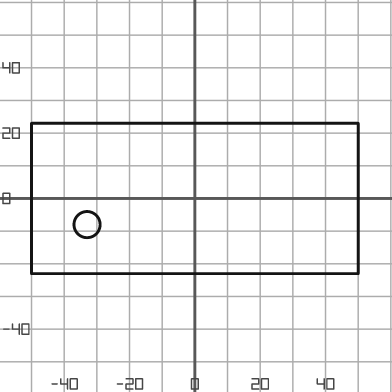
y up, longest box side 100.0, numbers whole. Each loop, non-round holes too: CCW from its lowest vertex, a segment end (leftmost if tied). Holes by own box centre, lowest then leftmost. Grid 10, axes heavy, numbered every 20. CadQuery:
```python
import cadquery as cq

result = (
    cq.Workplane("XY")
    .moveTo(-50.0, -23.0)
    .lineTo(50.0, -23.0)
    .lineTo(50.0, 23.0)
    .lineTo(-50.0, 23.0)
    .close()
    .moveTo(-33.0, -8.0)
    .circle(4.0)
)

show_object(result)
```